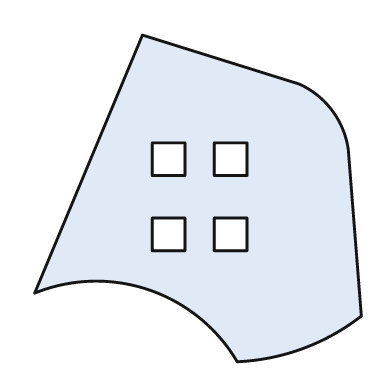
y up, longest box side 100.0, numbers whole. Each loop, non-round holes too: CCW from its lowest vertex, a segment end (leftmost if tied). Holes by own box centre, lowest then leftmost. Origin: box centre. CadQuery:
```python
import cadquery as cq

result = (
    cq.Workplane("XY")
    .moveTo(12.0, -50.0)
    .threePointArc((32.0, -46.0), (50.0, -36.0))
    .lineTo(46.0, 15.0)
    .threePointArc((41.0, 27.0), (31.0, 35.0))
    .lineTo(-17.0, 50.0)
    .lineTo(-50.0, -29.0)
    .threePointArc((-15.0, -28.0), (12.0, -50.0))
    .close()
    .moveTo(-14.0, -16.0)
    .lineTo(-4.0, -16.0)
    .lineTo(-4.0, -6.0)
    .lineTo(-14.0, -6.0)
    .close()
    .moveTo(5.0, -16.0)
    .lineTo(15.0, -16.0)
    .lineTo(15.0, -6.0)
    .lineTo(5.0, -6.0)
    .close()
    .moveTo(-14.0, 7.0)
    .lineTo(-4.0, 7.0)
    .lineTo(-4.0, 17.0)
    .lineTo(-14.0, 17.0)
    .close()
    .moveTo(5.0, 7.0)
    .lineTo(15.0, 7.0)
    .lineTo(15.0, 17.0)
    .lineTo(5.0, 17.0)
    .close()
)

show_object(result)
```